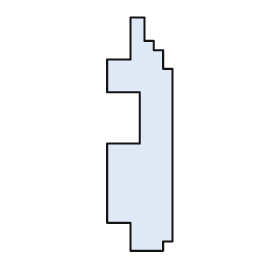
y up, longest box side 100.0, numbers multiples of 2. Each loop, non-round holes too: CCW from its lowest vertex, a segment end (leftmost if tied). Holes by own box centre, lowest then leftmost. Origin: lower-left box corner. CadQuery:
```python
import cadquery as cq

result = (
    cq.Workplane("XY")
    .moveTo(10.0, 0.0)
    .lineTo(24.0, 0.0)
    .lineTo(24.0, 4.0)
    .lineTo(28.0, 4.0)
    .lineTo(28.0, 78.0)
    .lineTo(24.0, 78.0)
    .lineTo(24.0, 86.0)
    .lineTo(20.0, 86.0)
    .lineTo(20.0, 90.0)
    .lineTo(16.0, 90.0)
    .lineTo(16.0, 100.0)
    .lineTo(10.0, 100.0)
    .lineTo(10.0, 82.0)
    .lineTo(0.0, 82.0)
    .lineTo(0.0, 68.0)
    .lineTo(14.0, 68.0)
    .lineTo(14.0, 46.0)
    .lineTo(0.0, 46.0)
    .lineTo(0.0, 12.0)
    .lineTo(10.0, 12.0)
    .close()
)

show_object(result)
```